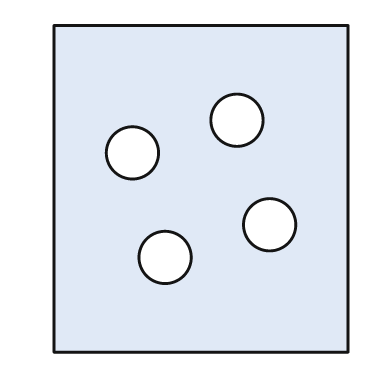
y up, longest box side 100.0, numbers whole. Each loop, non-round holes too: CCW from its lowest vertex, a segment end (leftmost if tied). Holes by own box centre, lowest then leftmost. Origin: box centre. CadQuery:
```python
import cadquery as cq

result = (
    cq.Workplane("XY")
    .moveTo(-45.0, -50.0)
    .lineTo(45.0, -50.0)
    .lineTo(45.0, 50.0)
    .lineTo(-45.0, 50.0)
    .close()
    .moveTo(-11.0, -21.0)
    .circle(8.0)
    .moveTo(21.0, -11.0)
    .circle(8.0)
    .moveTo(-21.0, 11.0)
    .circle(8.0)
    .moveTo(11.0, 21.0)
    .circle(8.0)
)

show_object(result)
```